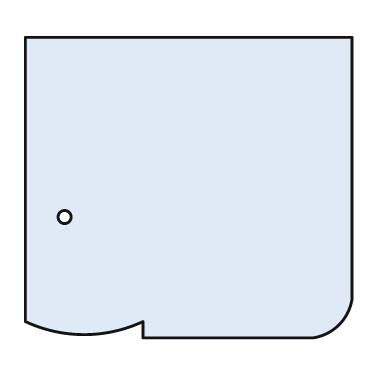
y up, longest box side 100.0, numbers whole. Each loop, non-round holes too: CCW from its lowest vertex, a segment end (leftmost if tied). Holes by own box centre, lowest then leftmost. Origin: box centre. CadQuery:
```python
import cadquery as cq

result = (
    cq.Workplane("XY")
    .moveTo(-14.0, -46.0)
    .lineTo(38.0, -46.0)
    .threePointArc((46.0, -42.0), (50.0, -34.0))
    .lineTo(50.0, 46.0)
    .lineTo(-50.0, 46.0)
    .lineTo(-50.0, -41.0)
    .threePointArc((-32.0, -45.0), (-14.0, -41.0))
    .close()
    .moveTo(-38.0, -9.0)
    .circle(2.0)
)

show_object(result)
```